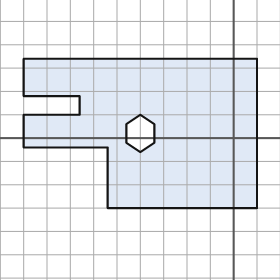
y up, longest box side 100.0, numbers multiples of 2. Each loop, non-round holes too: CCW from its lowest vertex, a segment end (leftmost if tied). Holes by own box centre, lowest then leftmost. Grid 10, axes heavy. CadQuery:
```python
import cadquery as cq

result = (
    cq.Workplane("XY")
    .moveTo(-54.0, -30.0)
    .lineTo(10.0, -30.0)
    .lineTo(10.0, 34.0)
    .lineTo(-90.0, 34.0)
    .lineTo(-90.0, 18.0)
    .lineTo(-66.0, 18.0)
    .lineTo(-66.0, 10.0)
    .lineTo(-90.0, 10.0)
    .lineTo(-90.0, -4.0)
    .lineTo(-54.0, -4.0)
    .close()
    .moveTo(-40.0, -6.0)
    .lineTo(-34.0, -2.0)
    .lineTo(-34.0, 6.0)
    .lineTo(-40.0, 10.0)
    .lineTo(-46.0, 6.0)
    .lineTo(-46.0, -2.0)
    .close()
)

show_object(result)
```